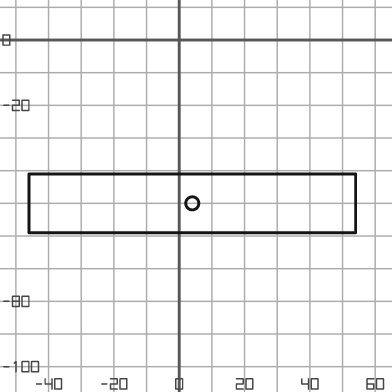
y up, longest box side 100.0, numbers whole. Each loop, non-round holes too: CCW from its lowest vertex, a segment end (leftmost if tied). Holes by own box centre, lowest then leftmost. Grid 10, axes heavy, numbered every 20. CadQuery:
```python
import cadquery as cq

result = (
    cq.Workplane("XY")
    .moveTo(-46.0, -59.0)
    .lineTo(54.0, -59.0)
    .lineTo(54.0, -41.0)
    .lineTo(-46.0, -41.0)
    .close()
    .moveTo(4.0, -50.0)
    .circle(2.0)
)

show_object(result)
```